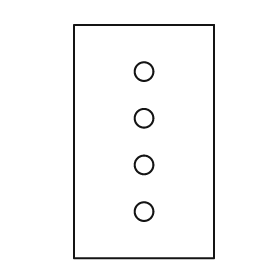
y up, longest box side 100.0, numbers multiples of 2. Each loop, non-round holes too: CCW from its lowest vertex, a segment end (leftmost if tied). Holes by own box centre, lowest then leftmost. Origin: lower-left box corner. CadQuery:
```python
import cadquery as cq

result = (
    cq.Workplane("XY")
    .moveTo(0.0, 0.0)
    .lineTo(60.0, 0.0)
    .lineTo(60.0, 100.0)
    .lineTo(0.0, 100.0)
    .close()
    .moveTo(30.0, 20.0)
    .circle(4.0)
    .moveTo(30.0, 40.0)
    .circle(4.0)
    .moveTo(30.0, 60.0)
    .circle(4.0)
    .moveTo(30.0, 80.0)
    .circle(4.0)
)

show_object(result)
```